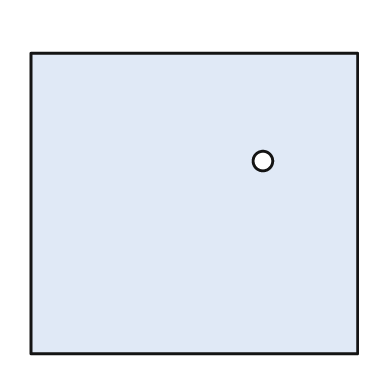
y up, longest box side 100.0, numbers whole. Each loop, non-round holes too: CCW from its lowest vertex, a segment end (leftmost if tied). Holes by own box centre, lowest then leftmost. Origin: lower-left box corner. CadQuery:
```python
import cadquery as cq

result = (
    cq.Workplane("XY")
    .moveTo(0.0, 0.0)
    .lineTo(100.0, 0.0)
    .lineTo(100.0, 92.0)
    .lineTo(0.0, 92.0)
    .close()
    .moveTo(71.0, 59.0)
    .circle(3.0)
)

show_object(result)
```